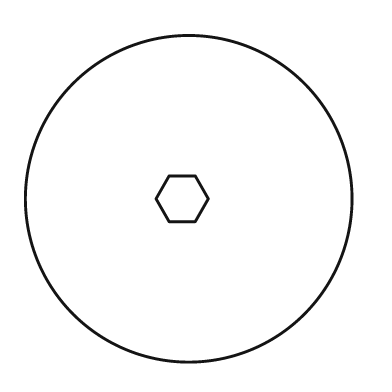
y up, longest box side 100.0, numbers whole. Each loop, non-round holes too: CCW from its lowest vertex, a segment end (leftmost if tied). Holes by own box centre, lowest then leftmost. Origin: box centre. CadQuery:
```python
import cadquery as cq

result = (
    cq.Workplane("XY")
    .moveTo(0.0, 0.0)
    .circle(50.0)
    .moveTo(-6.0, -7.0)
    .lineTo(2.0, -7.0)
    .lineTo(6.0, 0.0)
    .lineTo(2.0, 7.0)
    .lineTo(-6.0, 7.0)
    .lineTo(-10.0, 0.0)
    .close()
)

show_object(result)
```